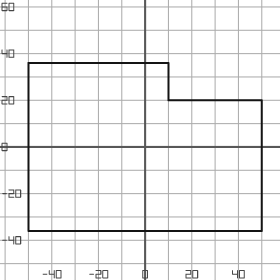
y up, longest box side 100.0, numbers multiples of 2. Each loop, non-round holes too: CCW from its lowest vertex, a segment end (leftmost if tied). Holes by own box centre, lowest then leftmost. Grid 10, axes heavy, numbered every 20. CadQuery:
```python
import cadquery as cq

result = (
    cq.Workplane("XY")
    .moveTo(-50.0, -36.0)
    .lineTo(50.0, -36.0)
    .lineTo(50.0, 20.0)
    .lineTo(10.0, 20.0)
    .lineTo(10.0, 36.0)
    .lineTo(-50.0, 36.0)
    .close()
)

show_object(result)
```